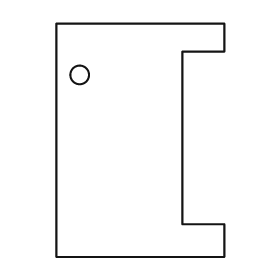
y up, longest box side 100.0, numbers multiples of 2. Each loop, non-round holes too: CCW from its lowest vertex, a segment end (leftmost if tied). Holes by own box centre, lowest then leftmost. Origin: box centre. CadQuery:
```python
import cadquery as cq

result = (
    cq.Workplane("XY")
    .moveTo(-36.0, -50.0)
    .lineTo(36.0, -50.0)
    .lineTo(36.0, -36.0)
    .lineTo(18.0, -36.0)
    .lineTo(18.0, 38.0)
    .lineTo(36.0, 38.0)
    .lineTo(36.0, 50.0)
    .lineTo(-36.0, 50.0)
    .close()
    .moveTo(-26.0, 28.0)
    .circle(4.0)
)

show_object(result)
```